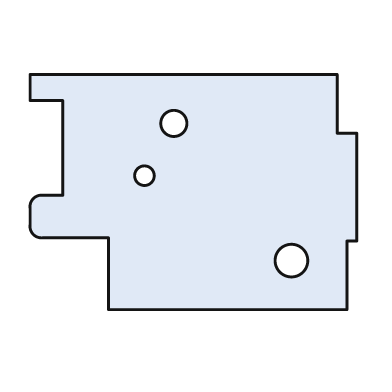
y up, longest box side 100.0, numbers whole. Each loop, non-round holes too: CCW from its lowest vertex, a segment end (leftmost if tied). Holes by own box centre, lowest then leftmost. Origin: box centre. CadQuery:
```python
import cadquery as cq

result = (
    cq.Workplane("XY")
    .moveTo(-26.0, -36.0)
    .lineTo(47.0, -36.0)
    .lineTo(47.0, -15.0)
    .lineTo(50.0, -15.0)
    .lineTo(50.0, 18.0)
    .lineTo(44.0, 18.0)
    .lineTo(44.0, 36.0)
    .lineTo(-50.0, 36.0)
    .lineTo(-50.0, 28.0)
    .lineTo(-40.0, 28.0)
    .lineTo(-40.0, -1.0)
    .lineTo(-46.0, -1.0)
    .threePointArc((-49.0, -2.0), (-50.0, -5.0))
    .lineTo(-50.0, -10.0)
    .threePointArc((-49.0, -13.0), (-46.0, -14.0))
    .lineTo(-26.0, -14.0)
    .close()
    .moveTo(30.0, -21.0)
    .circle(5.0)
    .moveTo(-15.0, 5.0)
    .circle(3.0)
    .moveTo(-6.0, 21.0)
    .circle(4.0)
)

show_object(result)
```